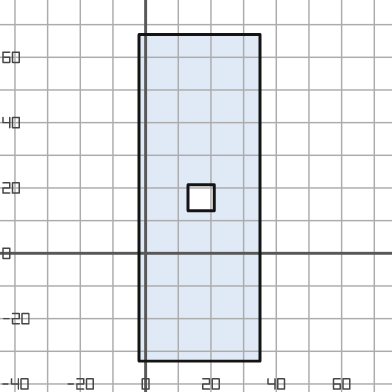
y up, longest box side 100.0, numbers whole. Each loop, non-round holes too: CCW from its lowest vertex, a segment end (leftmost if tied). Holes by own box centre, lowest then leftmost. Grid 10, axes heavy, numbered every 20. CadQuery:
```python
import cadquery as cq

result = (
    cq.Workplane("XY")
    .moveTo(-2.0, -33.0)
    .lineTo(35.0, -33.0)
    .lineTo(35.0, 67.0)
    .lineTo(-2.0, 67.0)
    .close()
    .moveTo(13.0, 13.0)
    .lineTo(21.0, 13.0)
    .lineTo(21.0, 21.0)
    .lineTo(13.0, 21.0)
    .close()
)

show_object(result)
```